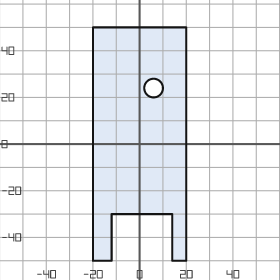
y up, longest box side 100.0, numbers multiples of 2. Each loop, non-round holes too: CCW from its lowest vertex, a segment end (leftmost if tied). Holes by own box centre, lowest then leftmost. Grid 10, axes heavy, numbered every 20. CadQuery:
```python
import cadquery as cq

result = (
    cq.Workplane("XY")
    .moveTo(-20.0, -50.0)
    .lineTo(-12.0, -50.0)
    .lineTo(-12.0, -30.0)
    .lineTo(14.0, -30.0)
    .lineTo(14.0, -50.0)
    .lineTo(20.0, -50.0)
    .lineTo(20.0, 50.0)
    .lineTo(-20.0, 50.0)
    .close()
    .moveTo(6.0, 24.0)
    .circle(4.0)
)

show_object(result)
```